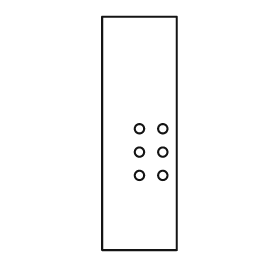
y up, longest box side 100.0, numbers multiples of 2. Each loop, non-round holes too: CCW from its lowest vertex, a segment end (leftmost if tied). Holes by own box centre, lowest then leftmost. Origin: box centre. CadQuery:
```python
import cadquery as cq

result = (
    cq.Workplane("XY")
    .moveTo(-16.0, -50.0)
    .lineTo(16.0, -50.0)
    .lineTo(16.0, 50.0)
    .lineTo(-16.0, 50.0)
    .close()
    .moveTo(0.0, -18.0)
    .circle(2.0)
    .moveTo(10.0, -18.0)
    .circle(2.0)
    .moveTo(0.0, -8.0)
    .circle(2.0)
    .moveTo(10.0, -8.0)
    .circle(2.0)
    .moveTo(0.0, 2.0)
    .circle(2.0)
    .moveTo(10.0, 2.0)
    .circle(2.0)
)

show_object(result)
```